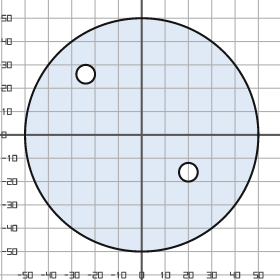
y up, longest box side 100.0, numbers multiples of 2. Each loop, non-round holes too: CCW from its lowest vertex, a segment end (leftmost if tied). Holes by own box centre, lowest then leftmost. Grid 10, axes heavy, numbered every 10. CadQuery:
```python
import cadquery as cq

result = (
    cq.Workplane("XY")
    .moveTo(0.0, 0.0)
    .circle(50.0)
    .moveTo(20.0, -16.0)
    .circle(4.0)
    .moveTo(-24.0, 26.0)
    .circle(4.0)
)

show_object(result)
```